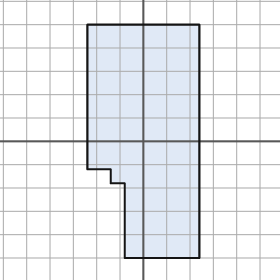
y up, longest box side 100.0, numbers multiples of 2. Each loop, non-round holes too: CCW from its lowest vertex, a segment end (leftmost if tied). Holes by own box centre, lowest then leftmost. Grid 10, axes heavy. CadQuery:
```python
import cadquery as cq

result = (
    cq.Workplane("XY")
    .moveTo(-8.0, -50.0)
    .lineTo(24.0, -50.0)
    .lineTo(24.0, 50.0)
    .lineTo(-24.0, 50.0)
    .lineTo(-24.0, -12.0)
    .lineTo(-14.0, -12.0)
    .lineTo(-14.0, -18.0)
    .lineTo(-8.0, -18.0)
    .close()
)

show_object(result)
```